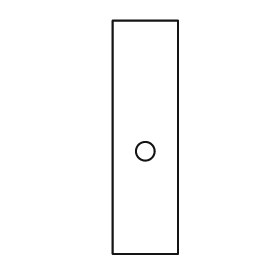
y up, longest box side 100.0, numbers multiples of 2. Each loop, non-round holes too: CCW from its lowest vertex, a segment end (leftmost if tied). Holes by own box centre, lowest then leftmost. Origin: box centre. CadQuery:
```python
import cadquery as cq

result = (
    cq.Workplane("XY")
    .moveTo(-14.0, -50.0)
    .lineTo(14.0, -50.0)
    .lineTo(14.0, 50.0)
    .lineTo(-14.0, 50.0)
    .close()
    .moveTo(0.0, -6.0)
    .circle(4.0)
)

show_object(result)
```